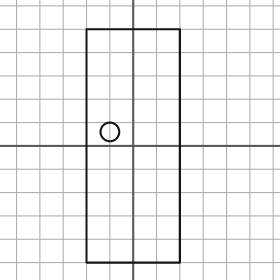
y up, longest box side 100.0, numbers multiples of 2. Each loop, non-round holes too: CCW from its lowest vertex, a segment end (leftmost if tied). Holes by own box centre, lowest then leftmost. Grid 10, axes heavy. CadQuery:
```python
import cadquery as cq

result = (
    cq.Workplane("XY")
    .moveTo(-20.0, -50.0)
    .lineTo(20.0, -50.0)
    .lineTo(20.0, 50.0)
    .lineTo(-20.0, 50.0)
    .close()
    .moveTo(-10.0, 6.0)
    .circle(4.0)
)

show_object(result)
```